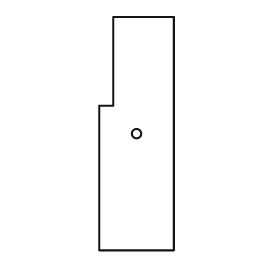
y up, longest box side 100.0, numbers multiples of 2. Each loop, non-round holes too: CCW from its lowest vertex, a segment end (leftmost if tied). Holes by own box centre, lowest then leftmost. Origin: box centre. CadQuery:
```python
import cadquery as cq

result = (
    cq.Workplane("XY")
    .moveTo(-16.0, -50.0)
    .lineTo(16.0, -50.0)
    .lineTo(16.0, 50.0)
    .lineTo(-10.0, 50.0)
    .lineTo(-10.0, 12.0)
    .lineTo(-16.0, 12.0)
    .close()
    .moveTo(0.0, 0.0)
    .circle(2.0)
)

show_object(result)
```